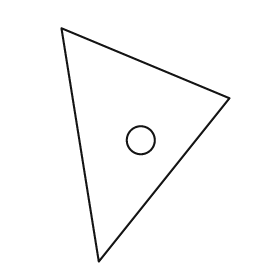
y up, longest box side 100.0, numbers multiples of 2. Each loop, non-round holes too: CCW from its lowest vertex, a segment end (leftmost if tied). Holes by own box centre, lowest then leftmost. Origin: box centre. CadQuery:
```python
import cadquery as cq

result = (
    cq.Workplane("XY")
    .moveTo(-20.0, -50.0)
    .lineTo(36.0, 20.0)
    .lineTo(-36.0, 50.0)
    .close()
    .moveTo(-2.0, 2.0)
    .circle(6.0)
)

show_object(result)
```